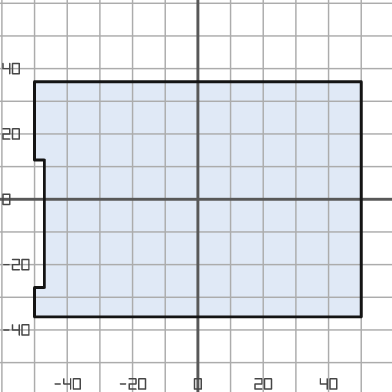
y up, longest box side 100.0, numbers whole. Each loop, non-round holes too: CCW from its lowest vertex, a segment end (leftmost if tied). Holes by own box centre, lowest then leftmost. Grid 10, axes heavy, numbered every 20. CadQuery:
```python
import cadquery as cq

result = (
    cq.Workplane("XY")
    .moveTo(-50.0, -36.0)
    .lineTo(50.0, -36.0)
    .lineTo(50.0, 36.0)
    .lineTo(-50.0, 36.0)
    .lineTo(-50.0, 12.0)
    .lineTo(-47.0, 12.0)
    .lineTo(-47.0, -27.0)
    .lineTo(-50.0, -27.0)
    .close()
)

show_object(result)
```